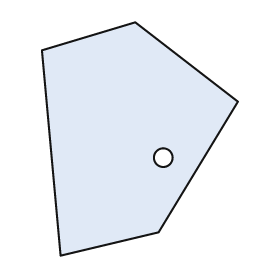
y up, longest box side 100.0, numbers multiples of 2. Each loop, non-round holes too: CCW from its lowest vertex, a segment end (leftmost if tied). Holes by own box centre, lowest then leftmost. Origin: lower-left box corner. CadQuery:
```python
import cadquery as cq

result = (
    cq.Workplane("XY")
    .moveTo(8.0, 0.0)
    .lineTo(50.0, 10.0)
    .lineTo(84.0, 66.0)
    .lineTo(40.0, 100.0)
    .lineTo(0.0, 88.0)
    .close()
    .moveTo(52.0, 42.0)
    .circle(4.0)
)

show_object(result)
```